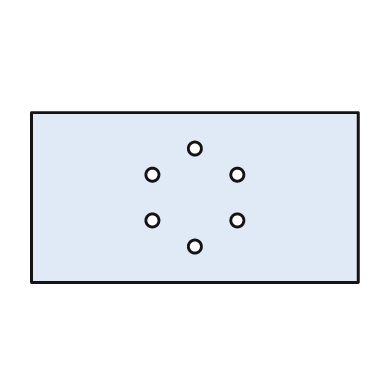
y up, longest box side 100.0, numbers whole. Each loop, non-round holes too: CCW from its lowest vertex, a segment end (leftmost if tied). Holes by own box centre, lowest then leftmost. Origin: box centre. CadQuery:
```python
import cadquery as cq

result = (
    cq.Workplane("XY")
    .moveTo(-50.0, -26.0)
    .lineTo(50.0, -26.0)
    .lineTo(50.0, 26.0)
    .lineTo(-50.0, 26.0)
    .close()
    .moveTo(0.0, -15.0)
    .circle(2.0)
    .moveTo(-13.0, -7.0)
    .circle(2.0)
    .moveTo(13.0, -7.0)
    .circle(2.0)
    .moveTo(-13.0, 7.0)
    .circle(2.0)
    .moveTo(13.0, 7.0)
    .circle(2.0)
    .moveTo(0.0, 15.0)
    .circle(2.0)
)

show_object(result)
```